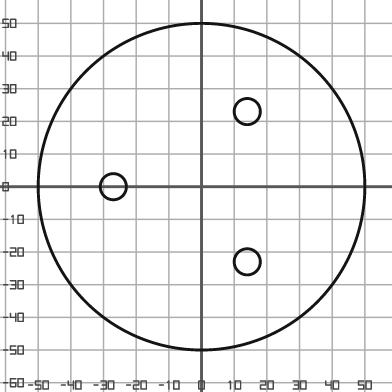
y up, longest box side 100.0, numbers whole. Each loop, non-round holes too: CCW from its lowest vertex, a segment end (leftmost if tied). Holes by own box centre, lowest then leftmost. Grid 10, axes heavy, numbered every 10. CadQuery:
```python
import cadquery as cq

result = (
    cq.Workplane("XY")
    .moveTo(0.0, 0.0)
    .circle(50.0)
    .moveTo(14.0, -23.0)
    .circle(4.0)
    .moveTo(-27.0, 0.0)
    .circle(4.0)
    .moveTo(14.0, 23.0)
    .circle(4.0)
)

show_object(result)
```